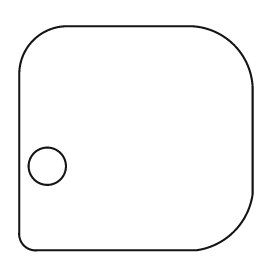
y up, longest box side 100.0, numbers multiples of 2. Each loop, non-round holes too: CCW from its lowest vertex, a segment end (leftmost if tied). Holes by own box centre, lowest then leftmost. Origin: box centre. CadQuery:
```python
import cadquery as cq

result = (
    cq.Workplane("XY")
    .moveTo(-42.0, -48.0)
    .lineTo(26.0, -48.0)
    .threePointArc((42.0, -40.0), (50.0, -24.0))
    .lineTo(50.0, 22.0)
    .threePointArc((42.0, 40.0), (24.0, 48.0))
    .lineTo(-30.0, 48.0)
    .threePointArc((-44.0, 42.0), (-50.0, 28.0))
    .lineTo(-50.0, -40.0)
    .threePointArc((-48.0, -46.0), (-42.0, -48.0))
    .close()
    .moveTo(-38.0, -12.0)
    .circle(8.0)
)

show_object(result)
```